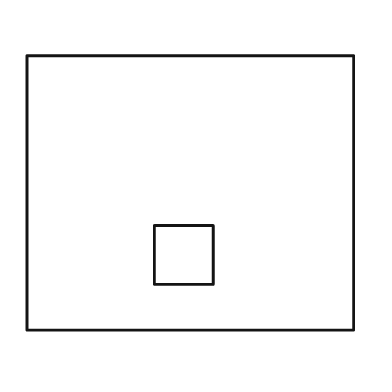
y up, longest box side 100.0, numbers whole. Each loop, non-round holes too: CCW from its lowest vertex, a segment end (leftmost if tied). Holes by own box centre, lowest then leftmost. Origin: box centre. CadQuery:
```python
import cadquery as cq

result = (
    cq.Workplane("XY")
    .moveTo(-50.0, -42.0)
    .lineTo(50.0, -42.0)
    .lineTo(50.0, 42.0)
    .lineTo(-50.0, 42.0)
    .close()
    .moveTo(-11.0, -28.0)
    .lineTo(7.0, -28.0)
    .lineTo(7.0, -10.0)
    .lineTo(-11.0, -10.0)
    .close()
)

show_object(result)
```